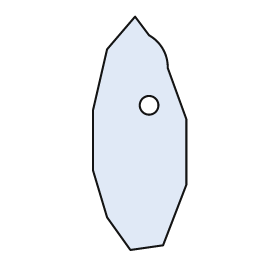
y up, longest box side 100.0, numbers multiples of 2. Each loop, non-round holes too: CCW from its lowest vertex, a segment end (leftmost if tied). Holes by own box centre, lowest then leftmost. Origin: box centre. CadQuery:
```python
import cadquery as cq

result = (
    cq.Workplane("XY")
    .moveTo(-4.0, -50.0)
    .lineTo(10.0, -48.0)
    .lineTo(20.0, -22.0)
    .lineTo(20.0, 6.0)
    .lineTo(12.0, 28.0)
    .threePointArc((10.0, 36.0), (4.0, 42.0))
    .lineTo(-2.0, 50.0)
    .lineTo(-14.0, 36.0)
    .lineTo(-20.0, 10.0)
    .lineTo(-20.0, -16.0)
    .lineTo(-14.0, -36.0)
    .close()
    .moveTo(4.0, 12.0)
    .circle(4.0)
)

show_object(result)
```